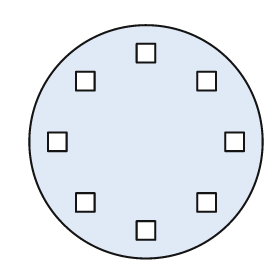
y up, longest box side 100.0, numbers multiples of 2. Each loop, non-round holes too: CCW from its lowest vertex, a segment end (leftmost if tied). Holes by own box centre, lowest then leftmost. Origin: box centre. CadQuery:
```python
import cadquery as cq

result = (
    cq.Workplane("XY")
    .moveTo(0.0, 0.0)
    .circle(50.0)
    .moveTo(-4.0, -42.0)
    .lineTo(4.0, -42.0)
    .lineTo(4.0, -34.0)
    .lineTo(-4.0, -34.0)
    .close()
    .moveTo(-30.0, -30.0)
    .lineTo(-22.0, -30.0)
    .lineTo(-22.0, -22.0)
    .lineTo(-30.0, -22.0)
    .close()
    .moveTo(22.0, -30.0)
    .lineTo(30.0, -30.0)
    .lineTo(30.0, -22.0)
    .lineTo(22.0, -22.0)
    .close()
    .moveTo(-42.0, -4.0)
    .lineTo(-34.0, -4.0)
    .lineTo(-34.0, 4.0)
    .lineTo(-42.0, 4.0)
    .close()
    .moveTo(34.0, -4.0)
    .lineTo(42.0, -4.0)
    .lineTo(42.0, 4.0)
    .lineTo(34.0, 4.0)
    .close()
    .moveTo(-30.0, 22.0)
    .lineTo(-22.0, 22.0)
    .lineTo(-22.0, 30.0)
    .lineTo(-30.0, 30.0)
    .close()
    .moveTo(22.0, 22.0)
    .lineTo(30.0, 22.0)
    .lineTo(30.0, 30.0)
    .lineTo(22.0, 30.0)
    .close()
    .moveTo(-4.0, 34.0)
    .lineTo(4.0, 34.0)
    .lineTo(4.0, 42.0)
    .lineTo(-4.0, 42.0)
    .close()
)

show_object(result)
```